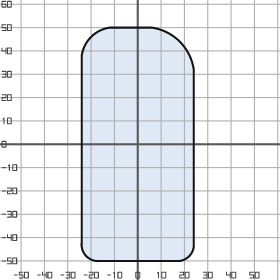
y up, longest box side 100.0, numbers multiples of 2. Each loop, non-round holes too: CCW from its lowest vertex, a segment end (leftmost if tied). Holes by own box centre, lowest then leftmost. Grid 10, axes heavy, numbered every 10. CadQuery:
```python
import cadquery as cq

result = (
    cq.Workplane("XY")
    .moveTo(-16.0, -50.0)
    .lineTo(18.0, -50.0)
    .threePointArc((22.0, -48.0), (24.0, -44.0))
    .lineTo(24.0, 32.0)
    .threePointArc((18.0, 44.0), (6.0, 50.0))
    .lineTo(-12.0, 50.0)
    .threePointArc((-20.0, 46.0), (-24.0, 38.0))
    .lineTo(-24.0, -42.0)
    .threePointArc((-22.0, -48.0), (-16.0, -50.0))
    .close()
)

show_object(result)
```